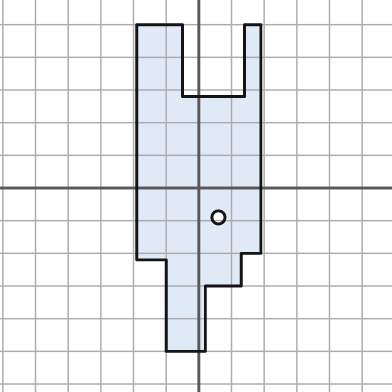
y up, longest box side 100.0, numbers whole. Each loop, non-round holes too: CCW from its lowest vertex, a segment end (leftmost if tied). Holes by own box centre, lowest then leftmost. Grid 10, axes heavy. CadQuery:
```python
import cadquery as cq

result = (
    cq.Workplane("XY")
    .moveTo(-10.0, -50.0)
    .lineTo(2.0, -50.0)
    .lineTo(2.0, -30.0)
    .lineTo(13.0, -30.0)
    .lineTo(13.0, -20.0)
    .lineTo(19.0, -20.0)
    .lineTo(19.0, 50.0)
    .lineTo(14.0, 50.0)
    .lineTo(14.0, 28.0)
    .lineTo(-5.0, 28.0)
    .lineTo(-5.0, 50.0)
    .lineTo(-19.0, 50.0)
    .lineTo(-19.0, -22.0)
    .lineTo(-10.0, -22.0)
    .close()
    .moveTo(6.0, -9.0)
    .circle(2.0)
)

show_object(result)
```